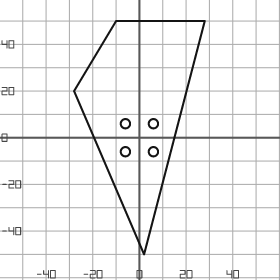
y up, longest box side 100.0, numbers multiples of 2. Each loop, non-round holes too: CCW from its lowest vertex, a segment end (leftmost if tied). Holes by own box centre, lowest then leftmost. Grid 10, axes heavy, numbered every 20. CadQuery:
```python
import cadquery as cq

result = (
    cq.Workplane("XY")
    .moveTo(2.0, -50.0)
    .lineTo(28.0, 50.0)
    .lineTo(-10.0, 50.0)
    .lineTo(-28.0, 20.0)
    .close()
    .moveTo(-6.0, -6.0)
    .circle(2.0)
    .moveTo(6.0, -6.0)
    .circle(2.0)
    .moveTo(-6.0, 6.0)
    .circle(2.0)
    .moveTo(6.0, 6.0)
    .circle(2.0)
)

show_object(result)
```